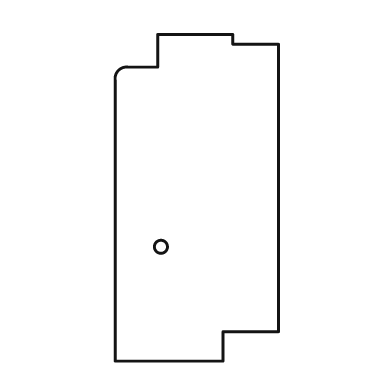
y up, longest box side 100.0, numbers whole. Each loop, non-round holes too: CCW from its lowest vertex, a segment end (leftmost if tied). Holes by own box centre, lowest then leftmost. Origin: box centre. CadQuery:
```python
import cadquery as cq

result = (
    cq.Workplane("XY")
    .moveTo(-25.0, -50.0)
    .lineTo(8.0, -50.0)
    .lineTo(8.0, -41.0)
    .lineTo(25.0, -41.0)
    .lineTo(25.0, 47.0)
    .lineTo(11.0, 47.0)
    .lineTo(11.0, 50.0)
    .lineTo(-12.0, 50.0)
    .lineTo(-12.0, 40.0)
    .lineTo(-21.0, 40.0)
    .threePointArc((-24.0, 39.0), (-25.0, 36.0))
    .close()
    .moveTo(-11.0, -15.0)
    .circle(2.0)
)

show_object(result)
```